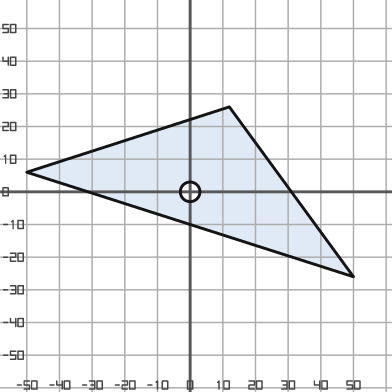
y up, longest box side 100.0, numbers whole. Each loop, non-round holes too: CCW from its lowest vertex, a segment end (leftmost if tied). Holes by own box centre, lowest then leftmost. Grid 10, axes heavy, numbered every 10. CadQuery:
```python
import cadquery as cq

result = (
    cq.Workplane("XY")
    .moveTo(50.0, -26.0)
    .lineTo(12.0, 26.0)
    .lineTo(-50.0, 6.0)
    .close()
    .moveTo(0.0, 0.0)
    .circle(3.0)
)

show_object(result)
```